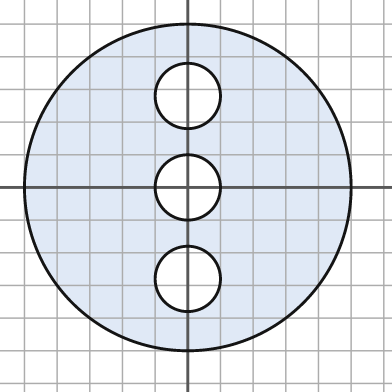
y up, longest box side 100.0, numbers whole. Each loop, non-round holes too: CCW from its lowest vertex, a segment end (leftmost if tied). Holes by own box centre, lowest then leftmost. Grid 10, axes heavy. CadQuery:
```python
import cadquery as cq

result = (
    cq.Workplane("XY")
    .moveTo(0.0, 0.0)
    .circle(50.0)
    .moveTo(0.0, -28.0)
    .circle(10.0)
    .moveTo(0.0, 0.0)
    .circle(10.0)
    .moveTo(0.0, 28.0)
    .circle(10.0)
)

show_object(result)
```